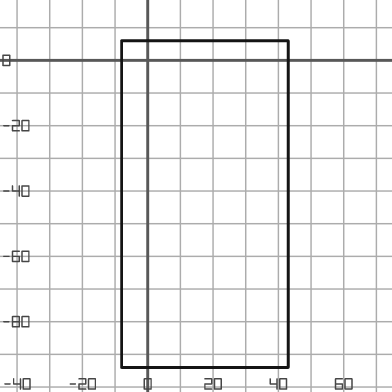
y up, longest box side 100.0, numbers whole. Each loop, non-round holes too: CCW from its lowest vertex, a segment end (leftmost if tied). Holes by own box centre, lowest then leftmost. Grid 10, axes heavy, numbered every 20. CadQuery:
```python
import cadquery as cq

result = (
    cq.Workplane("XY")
    .moveTo(-8.0, -94.0)
    .lineTo(43.0, -94.0)
    .lineTo(43.0, 6.0)
    .lineTo(-8.0, 6.0)
    .close()
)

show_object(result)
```